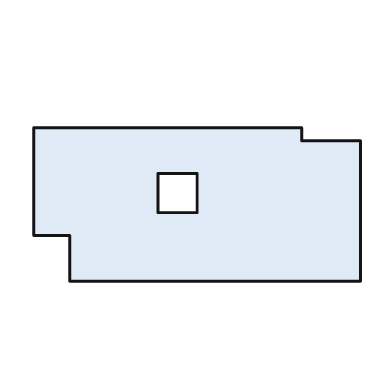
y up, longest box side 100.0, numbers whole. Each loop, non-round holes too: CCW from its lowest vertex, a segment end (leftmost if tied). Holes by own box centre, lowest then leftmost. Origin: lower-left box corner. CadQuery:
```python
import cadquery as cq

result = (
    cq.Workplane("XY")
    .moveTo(11.0, 0.0)
    .lineTo(100.0, 0.0)
    .lineTo(100.0, 43.0)
    .lineTo(82.0, 43.0)
    .lineTo(82.0, 47.0)
    .lineTo(0.0, 47.0)
    .lineTo(0.0, 14.0)
    .lineTo(11.0, 14.0)
    .close()
    .moveTo(38.0, 21.0)
    .lineTo(50.0, 21.0)
    .lineTo(50.0, 33.0)
    .lineTo(38.0, 33.0)
    .close()
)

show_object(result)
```